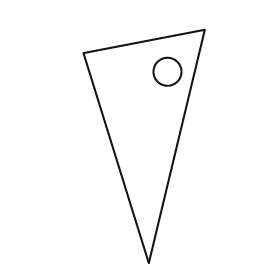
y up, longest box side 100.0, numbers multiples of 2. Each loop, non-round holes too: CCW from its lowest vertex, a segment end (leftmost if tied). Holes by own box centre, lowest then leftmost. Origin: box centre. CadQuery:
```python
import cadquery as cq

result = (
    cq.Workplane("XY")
    .moveTo(2.0, -50.0)
    .lineTo(26.0, 50.0)
    .lineTo(-26.0, 40.0)
    .close()
    .moveTo(10.0, 32.0)
    .circle(6.0)
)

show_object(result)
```